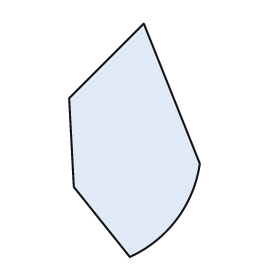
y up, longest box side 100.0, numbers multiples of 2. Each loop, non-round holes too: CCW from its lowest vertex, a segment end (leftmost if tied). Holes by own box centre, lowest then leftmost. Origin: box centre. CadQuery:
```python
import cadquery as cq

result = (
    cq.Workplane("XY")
    .moveTo(-2.0, -50.0)
    .threePointArc((18.0, -34.0), (28.0, -10.0))
    .lineTo(4.0, 50.0)
    .lineTo(-28.0, 18.0)
    .lineTo(-26.0, -20.0)
    .close()
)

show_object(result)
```